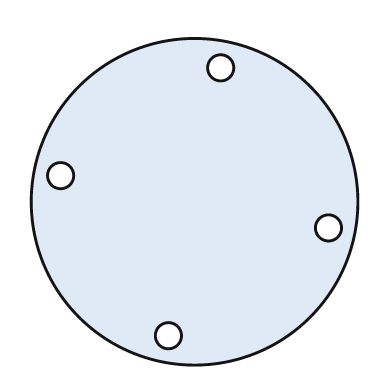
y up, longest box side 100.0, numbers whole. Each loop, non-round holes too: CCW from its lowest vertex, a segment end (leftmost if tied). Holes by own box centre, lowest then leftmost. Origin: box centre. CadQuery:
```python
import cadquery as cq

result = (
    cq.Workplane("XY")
    .moveTo(0.0, 0.0)
    .circle(50.0)
    .moveTo(-8.0, -41.0)
    .circle(4.0)
    .moveTo(41.0, -8.0)
    .circle(4.0)
    .moveTo(-41.0, 8.0)
    .circle(4.0)
    .moveTo(8.0, 41.0)
    .circle(4.0)
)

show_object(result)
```